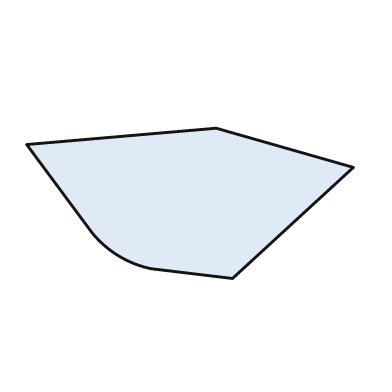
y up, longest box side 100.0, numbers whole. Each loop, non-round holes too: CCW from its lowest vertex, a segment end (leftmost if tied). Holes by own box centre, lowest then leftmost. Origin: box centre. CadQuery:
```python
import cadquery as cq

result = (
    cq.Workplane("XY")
    .moveTo(13.0, -23.0)
    .lineTo(50.0, 11.0)
    .lineTo(8.0, 23.0)
    .lineTo(-50.0, 18.0)
    .lineTo(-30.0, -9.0)
    .threePointArc((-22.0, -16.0), (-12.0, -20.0))
    .close()
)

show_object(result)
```